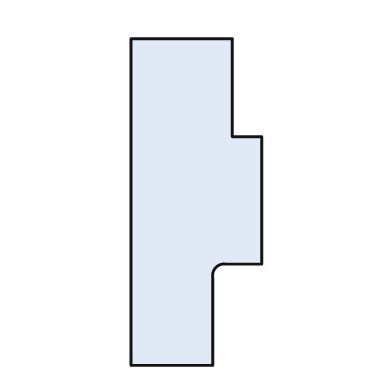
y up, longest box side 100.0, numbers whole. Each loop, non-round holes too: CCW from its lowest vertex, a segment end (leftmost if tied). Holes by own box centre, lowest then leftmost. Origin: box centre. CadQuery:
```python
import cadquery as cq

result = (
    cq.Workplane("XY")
    .moveTo(-20.0, -50.0)
    .lineTo(5.0, -50.0)
    .lineTo(5.0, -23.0)
    .threePointArc((6.0, -20.0), (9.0, -19.0))
    .lineTo(20.0, -19.0)
    .lineTo(20.0, 20.0)
    .lineTo(11.0, 20.0)
    .lineTo(11.0, 50.0)
    .lineTo(-20.0, 50.0)
    .close()
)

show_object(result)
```